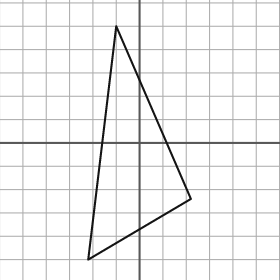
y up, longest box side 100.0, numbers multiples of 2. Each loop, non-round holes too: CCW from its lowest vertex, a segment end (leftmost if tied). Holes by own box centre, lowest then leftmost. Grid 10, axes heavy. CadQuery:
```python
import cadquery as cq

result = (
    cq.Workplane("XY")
    .moveTo(-22.0, -50.0)
    .lineTo(22.0, -24.0)
    .lineTo(-10.0, 50.0)
    .close()
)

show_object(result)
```